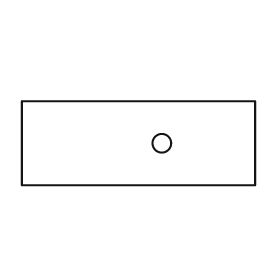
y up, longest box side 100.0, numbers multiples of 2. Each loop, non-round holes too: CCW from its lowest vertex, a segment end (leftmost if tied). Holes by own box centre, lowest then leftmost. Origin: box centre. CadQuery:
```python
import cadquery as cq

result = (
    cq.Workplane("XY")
    .moveTo(-50.0, -18.0)
    .lineTo(50.0, -18.0)
    .lineTo(50.0, 18.0)
    .lineTo(-50.0, 18.0)
    .close()
    .moveTo(10.0, 0.0)
    .circle(4.0)
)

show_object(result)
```